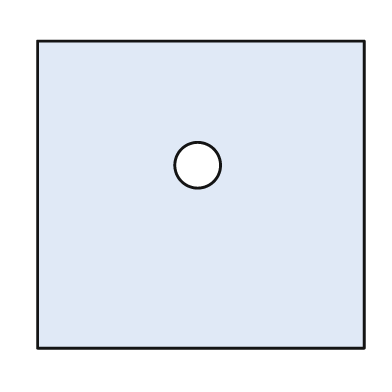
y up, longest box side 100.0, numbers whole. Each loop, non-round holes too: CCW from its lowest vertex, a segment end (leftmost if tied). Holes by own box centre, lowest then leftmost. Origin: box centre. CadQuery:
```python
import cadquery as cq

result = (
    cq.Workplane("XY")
    .moveTo(-50.0, -47.0)
    .lineTo(50.0, -47.0)
    .lineTo(50.0, 47.0)
    .lineTo(-50.0, 47.0)
    .close()
    .moveTo(-1.0, 9.0)
    .circle(7.0)
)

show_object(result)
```